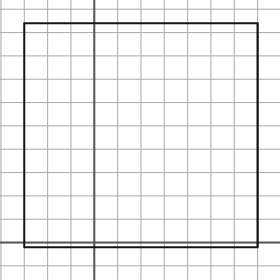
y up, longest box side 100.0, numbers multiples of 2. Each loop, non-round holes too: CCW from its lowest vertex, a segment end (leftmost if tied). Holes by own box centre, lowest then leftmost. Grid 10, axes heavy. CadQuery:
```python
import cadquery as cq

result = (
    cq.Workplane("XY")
    .moveTo(-30.0, -2.0)
    .lineTo(70.0, -2.0)
    .lineTo(70.0, 94.0)
    .lineTo(-30.0, 94.0)
    .close()
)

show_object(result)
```